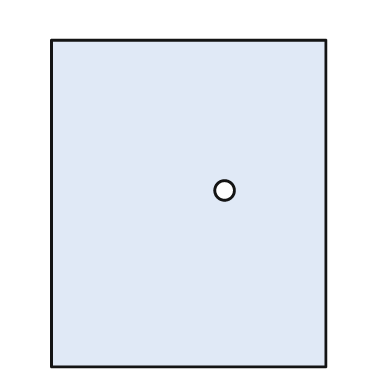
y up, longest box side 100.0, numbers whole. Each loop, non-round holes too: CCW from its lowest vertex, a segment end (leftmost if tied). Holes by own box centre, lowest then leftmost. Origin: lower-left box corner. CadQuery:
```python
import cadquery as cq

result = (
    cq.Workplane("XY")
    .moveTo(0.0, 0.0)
    .lineTo(84.0, 0.0)
    .lineTo(84.0, 100.0)
    .lineTo(0.0, 100.0)
    .close()
    .moveTo(53.0, 54.0)
    .circle(3.0)
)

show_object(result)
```